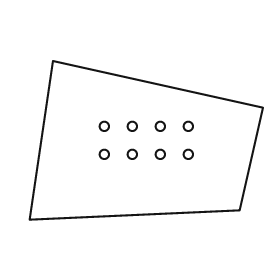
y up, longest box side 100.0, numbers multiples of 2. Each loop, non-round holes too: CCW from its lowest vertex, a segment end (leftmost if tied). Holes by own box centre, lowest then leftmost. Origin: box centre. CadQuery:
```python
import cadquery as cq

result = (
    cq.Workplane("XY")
    .moveTo(-50.0, -34.0)
    .lineTo(40.0, -30.0)
    .lineTo(50.0, 14.0)
    .lineTo(-40.0, 34.0)
    .close()
    .moveTo(-18.0, -6.0)
    .circle(2.0)
    .moveTo(-6.0, -6.0)
    .circle(2.0)
    .moveTo(6.0, -6.0)
    .circle(2.0)
    .moveTo(18.0, -6.0)
    .circle(2.0)
    .moveTo(-18.0, 6.0)
    .circle(2.0)
    .moveTo(-6.0, 6.0)
    .circle(2.0)
    .moveTo(6.0, 6.0)
    .circle(2.0)
    .moveTo(18.0, 6.0)
    .circle(2.0)
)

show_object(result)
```